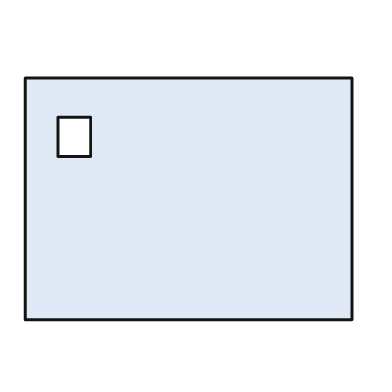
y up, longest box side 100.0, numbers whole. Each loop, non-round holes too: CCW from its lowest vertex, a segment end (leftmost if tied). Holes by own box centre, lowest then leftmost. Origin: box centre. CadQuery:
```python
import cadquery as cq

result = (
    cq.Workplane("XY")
    .moveTo(-50.0, -37.0)
    .lineTo(50.0, -37.0)
    .lineTo(50.0, 37.0)
    .lineTo(-50.0, 37.0)
    .close()
    .moveTo(-40.0, 13.0)
    .lineTo(-30.0, 13.0)
    .lineTo(-30.0, 25.0)
    .lineTo(-40.0, 25.0)
    .close()
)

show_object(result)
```